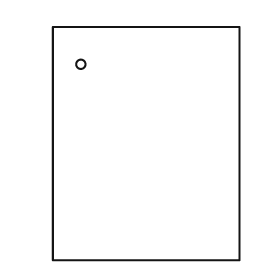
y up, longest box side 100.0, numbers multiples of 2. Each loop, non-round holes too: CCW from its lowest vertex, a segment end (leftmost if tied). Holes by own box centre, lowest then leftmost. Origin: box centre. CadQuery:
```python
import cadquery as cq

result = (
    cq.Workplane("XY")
    .moveTo(-40.0, -50.0)
    .lineTo(40.0, -50.0)
    .lineTo(40.0, 50.0)
    .lineTo(-40.0, 50.0)
    .close()
    .moveTo(-28.0, 34.0)
    .circle(2.0)
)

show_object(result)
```